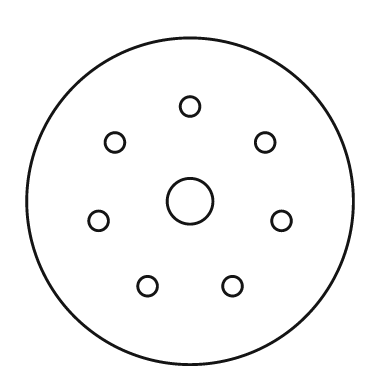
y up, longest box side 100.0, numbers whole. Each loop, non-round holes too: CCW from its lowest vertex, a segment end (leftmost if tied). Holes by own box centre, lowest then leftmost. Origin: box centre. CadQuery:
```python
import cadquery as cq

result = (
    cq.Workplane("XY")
    .moveTo(0.0, 0.0)
    .circle(50.0)
    .moveTo(-13.0, -26.0)
    .circle(3.0)
    .moveTo(13.0, -26.0)
    .circle(3.0)
    .moveTo(-28.0, -6.0)
    .circle(3.0)
    .moveTo(28.0, -6.0)
    .circle(3.0)
    .moveTo(0.0, 0.0)
    .circle(7.0)
    .moveTo(-23.0, 18.0)
    .circle(3.0)
    .moveTo(23.0, 18.0)
    .circle(3.0)
    .moveTo(0.0, 29.0)
    .circle(3.0)
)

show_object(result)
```